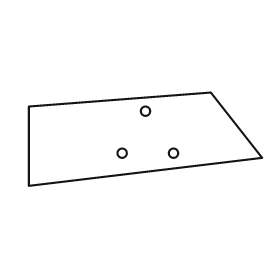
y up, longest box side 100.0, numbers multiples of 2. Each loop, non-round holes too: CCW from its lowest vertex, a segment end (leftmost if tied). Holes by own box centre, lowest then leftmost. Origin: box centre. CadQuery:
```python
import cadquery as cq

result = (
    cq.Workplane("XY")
    .moveTo(-50.0, -20.0)
    .lineTo(50.0, -8.0)
    .lineTo(28.0, 20.0)
    .lineTo(-50.0, 14.0)
    .close()
    .moveTo(-10.0, -6.0)
    .circle(2.0)
    .moveTo(12.0, -6.0)
    .circle(2.0)
    .moveTo(0.0, 12.0)
    .circle(2.0)
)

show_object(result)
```